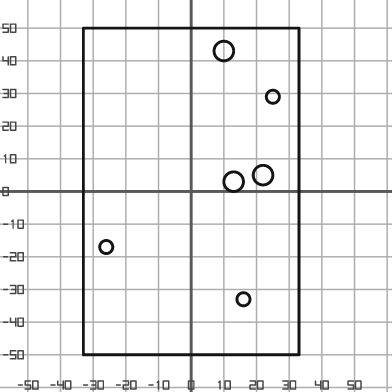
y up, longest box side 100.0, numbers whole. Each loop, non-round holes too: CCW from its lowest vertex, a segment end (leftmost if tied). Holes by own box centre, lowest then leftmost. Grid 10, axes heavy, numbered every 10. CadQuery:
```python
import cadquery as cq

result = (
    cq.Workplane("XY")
    .moveTo(-33.0, -50.0)
    .lineTo(33.0, -50.0)
    .lineTo(33.0, 50.0)
    .lineTo(-33.0, 50.0)
    .close()
    .moveTo(16.0, -33.0)
    .circle(2.0)
    .moveTo(-26.0, -17.0)
    .circle(2.0)
    .moveTo(13.0, 3.0)
    .circle(3.0)
    .moveTo(22.0, 5.0)
    .circle(3.0)
    .moveTo(25.0, 29.0)
    .circle(2.0)
    .moveTo(10.0, 43.0)
    .circle(3.0)
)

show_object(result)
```